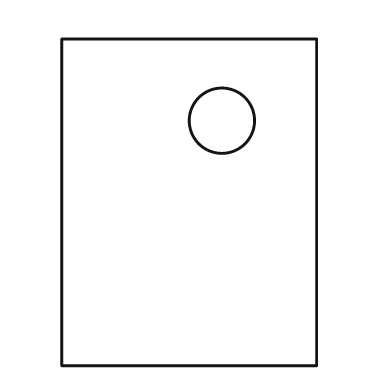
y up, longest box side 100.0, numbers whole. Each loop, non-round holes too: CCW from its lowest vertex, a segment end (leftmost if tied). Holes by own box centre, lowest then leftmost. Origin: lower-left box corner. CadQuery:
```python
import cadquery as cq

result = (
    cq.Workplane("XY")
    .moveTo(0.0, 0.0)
    .lineTo(78.0, 0.0)
    .lineTo(78.0, 100.0)
    .lineTo(0.0, 100.0)
    .close()
    .moveTo(49.0, 75.0)
    .circle(10.0)
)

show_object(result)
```